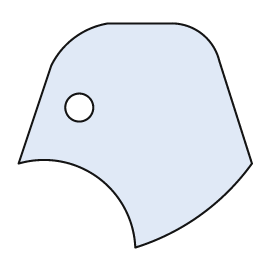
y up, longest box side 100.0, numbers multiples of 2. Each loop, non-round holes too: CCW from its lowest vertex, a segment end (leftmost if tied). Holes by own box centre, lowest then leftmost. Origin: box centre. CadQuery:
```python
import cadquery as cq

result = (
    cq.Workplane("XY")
    .moveTo(0.0, -48.0)
    .threePointArc((28.0, -34.0), (50.0, -12.0))
    .lineTo(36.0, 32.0)
    .threePointArc((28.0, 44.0), (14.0, 48.0))
    .lineTo(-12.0, 48.0)
    .threePointArc((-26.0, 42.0), (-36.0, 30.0))
    .lineTo(-50.0, -12.0)
    .threePointArc((-16.0, -18.0), (0.0, -48.0))
    .close()
    .moveTo(-24.0, 12.0)
    .circle(6.0)
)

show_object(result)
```